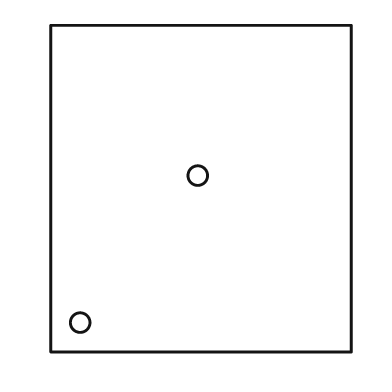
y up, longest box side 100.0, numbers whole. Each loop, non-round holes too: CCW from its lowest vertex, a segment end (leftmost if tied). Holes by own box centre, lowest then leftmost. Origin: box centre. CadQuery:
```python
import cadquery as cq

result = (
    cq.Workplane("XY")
    .moveTo(-46.0, -50.0)
    .lineTo(46.0, -50.0)
    .lineTo(46.0, 50.0)
    .lineTo(-46.0, 50.0)
    .close()
    .moveTo(-37.0, -41.0)
    .circle(3.0)
    .moveTo(-1.0, 4.0)
    .circle(3.0)
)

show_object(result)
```